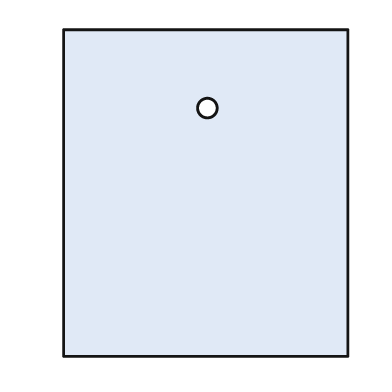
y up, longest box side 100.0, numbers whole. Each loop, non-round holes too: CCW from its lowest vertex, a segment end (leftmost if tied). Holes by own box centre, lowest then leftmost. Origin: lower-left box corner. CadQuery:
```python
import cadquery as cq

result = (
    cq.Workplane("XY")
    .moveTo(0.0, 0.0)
    .lineTo(87.0, 0.0)
    .lineTo(87.0, 100.0)
    .lineTo(0.0, 100.0)
    .close()
    .moveTo(44.0, 76.0)
    .circle(3.0)
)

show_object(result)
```